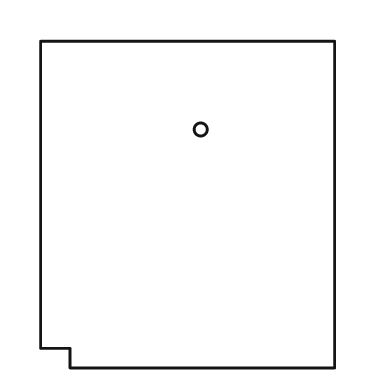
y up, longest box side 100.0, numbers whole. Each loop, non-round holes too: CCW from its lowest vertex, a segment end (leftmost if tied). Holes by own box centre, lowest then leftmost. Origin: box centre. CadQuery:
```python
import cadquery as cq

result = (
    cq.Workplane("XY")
    .moveTo(-36.0, -50.0)
    .lineTo(45.0, -50.0)
    .lineTo(45.0, 50.0)
    .lineTo(-45.0, 50.0)
    .lineTo(-45.0, -44.0)
    .lineTo(-36.0, -44.0)
    .close()
    .moveTo(4.0, 23.0)
    .circle(2.0)
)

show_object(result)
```